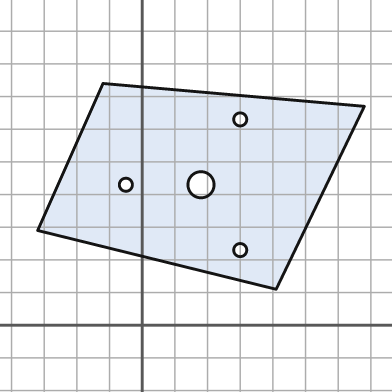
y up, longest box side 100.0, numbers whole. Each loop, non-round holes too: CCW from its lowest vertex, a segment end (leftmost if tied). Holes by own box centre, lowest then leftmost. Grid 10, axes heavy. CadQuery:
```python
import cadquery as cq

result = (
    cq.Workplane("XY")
    .moveTo(41.0, 11.0)
    .lineTo(68.0, 67.0)
    .lineTo(-12.0, 74.0)
    .lineTo(-32.0, 29.0)
    .close()
    .moveTo(30.0, 23.0)
    .circle(2.0)
    .moveTo(-5.0, 43.0)
    .circle(2.0)
    .moveTo(18.0, 43.0)
    .circle(4.0)
    .moveTo(30.0, 63.0)
    .circle(2.0)
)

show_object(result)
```